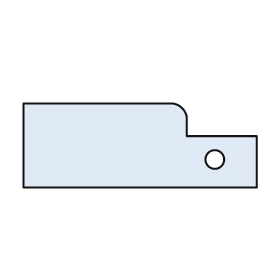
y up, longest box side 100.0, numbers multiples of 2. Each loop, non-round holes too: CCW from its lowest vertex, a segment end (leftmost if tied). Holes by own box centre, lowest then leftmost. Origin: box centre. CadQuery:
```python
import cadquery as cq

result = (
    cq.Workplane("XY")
    .moveTo(-50.0, -18.0)
    .lineTo(50.0, -18.0)
    .lineTo(50.0, 4.0)
    .lineTo(20.0, 4.0)
    .lineTo(20.0, 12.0)
    .threePointArc((18.0, 16.0), (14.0, 18.0))
    .lineTo(-50.0, 18.0)
    .close()
    .moveTo(32.0, -6.0)
    .circle(4.0)
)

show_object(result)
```